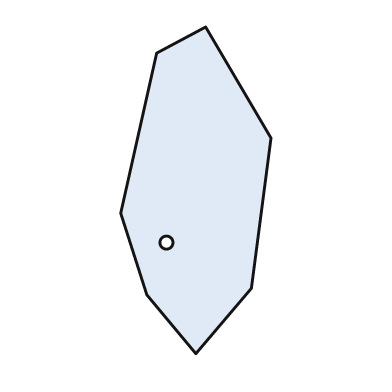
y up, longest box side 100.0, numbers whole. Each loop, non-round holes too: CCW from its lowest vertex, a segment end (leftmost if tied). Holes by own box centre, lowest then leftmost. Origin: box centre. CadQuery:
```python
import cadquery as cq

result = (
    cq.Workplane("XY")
    .moveTo(0.0, -50.0)
    .lineTo(17.0, -30.0)
    .lineTo(23.0, 16.0)
    .lineTo(3.0, 50.0)
    .lineTo(-12.0, 42.0)
    .lineTo(-23.0, -7.0)
    .lineTo(-15.0, -32.0)
    .close()
    .moveTo(-9.0, -16.0)
    .circle(2.0)
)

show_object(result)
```